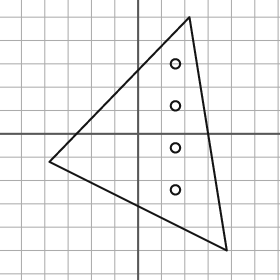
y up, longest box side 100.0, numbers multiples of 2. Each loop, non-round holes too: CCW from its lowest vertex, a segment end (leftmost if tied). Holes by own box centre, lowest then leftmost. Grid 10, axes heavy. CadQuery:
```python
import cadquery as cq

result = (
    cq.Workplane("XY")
    .moveTo(38.0, -50.0)
    .lineTo(22.0, 50.0)
    .lineTo(-38.0, -12.0)
    .close()
    .moveTo(16.0, -24.0)
    .circle(2.0)
    .moveTo(16.0, -6.0)
    .circle(2.0)
    .moveTo(16.0, 12.0)
    .circle(2.0)
    .moveTo(16.0, 30.0)
    .circle(2.0)
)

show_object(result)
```